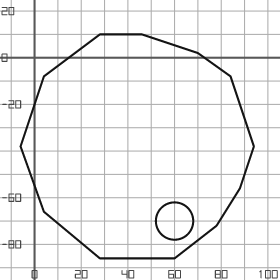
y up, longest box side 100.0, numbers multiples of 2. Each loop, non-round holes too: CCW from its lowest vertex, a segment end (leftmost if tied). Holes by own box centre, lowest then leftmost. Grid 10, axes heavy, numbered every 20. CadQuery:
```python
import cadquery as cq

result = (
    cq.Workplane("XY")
    .moveTo(28.0, -86.0)
    .lineTo(60.0, -86.0)
    .lineTo(78.0, -72.0)
    .lineTo(88.0, -56.0)
    .lineTo(94.0, -38.0)
    .lineTo(84.0, -8.0)
    .lineTo(70.0, 2.0)
    .lineTo(46.0, 10.0)
    .lineTo(28.0, 10.0)
    .lineTo(4.0, -8.0)
    .lineTo(-6.0, -38.0)
    .lineTo(4.0, -66.0)
    .close()
    .moveTo(60.0, -70.0)
    .circle(8.0)
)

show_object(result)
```